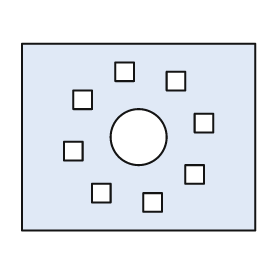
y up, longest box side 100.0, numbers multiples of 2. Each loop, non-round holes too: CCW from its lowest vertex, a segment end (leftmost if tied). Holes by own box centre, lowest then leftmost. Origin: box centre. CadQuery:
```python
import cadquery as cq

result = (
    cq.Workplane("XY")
    .moveTo(-50.0, -40.0)
    .lineTo(50.0, -40.0)
    .lineTo(50.0, 40.0)
    .lineTo(-50.0, 40.0)
    .close()
    .moveTo(2.0, -32.0)
    .lineTo(10.0, -32.0)
    .lineTo(10.0, -24.0)
    .lineTo(2.0, -24.0)
    .close()
    .moveTo(-20.0, -28.0)
    .lineTo(-12.0, -28.0)
    .lineTo(-12.0, -20.0)
    .lineTo(-20.0, -20.0)
    .close()
    .moveTo(20.0, -20.0)
    .lineTo(28.0, -20.0)
    .lineTo(28.0, -12.0)
    .lineTo(20.0, -12.0)
    .close()
    .moveTo(-32.0, -10.0)
    .lineTo(-24.0, -10.0)
    .lineTo(-24.0, -2.0)
    .lineTo(-32.0, -2.0)
    .close()
    .moveTo(0.0, 0.0)
    .circle(12.0)
    .moveTo(24.0, 2.0)
    .lineTo(32.0, 2.0)
    .lineTo(32.0, 10.0)
    .lineTo(24.0, 10.0)
    .close()
    .moveTo(-28.0, 12.0)
    .lineTo(-20.0, 12.0)
    .lineTo(-20.0, 20.0)
    .lineTo(-28.0, 20.0)
    .close()
    .moveTo(12.0, 20.0)
    .lineTo(20.0, 20.0)
    .lineTo(20.0, 28.0)
    .lineTo(12.0, 28.0)
    .close()
    .moveTo(-10.0, 24.0)
    .lineTo(-2.0, 24.0)
    .lineTo(-2.0, 32.0)
    .lineTo(-10.0, 32.0)
    .close()
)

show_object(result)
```